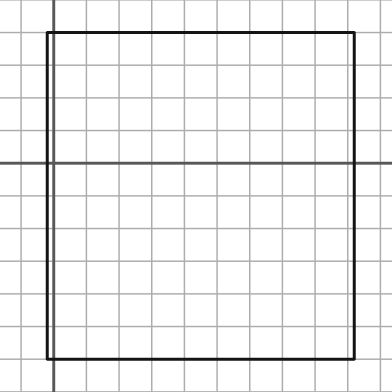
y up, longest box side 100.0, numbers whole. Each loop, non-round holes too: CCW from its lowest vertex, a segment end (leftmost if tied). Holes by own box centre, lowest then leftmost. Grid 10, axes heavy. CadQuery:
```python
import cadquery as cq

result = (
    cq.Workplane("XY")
    .moveTo(-2.0, -60.0)
    .lineTo(92.0, -60.0)
    .lineTo(92.0, 40.0)
    .lineTo(-2.0, 40.0)
    .close()
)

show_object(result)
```